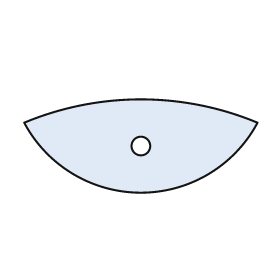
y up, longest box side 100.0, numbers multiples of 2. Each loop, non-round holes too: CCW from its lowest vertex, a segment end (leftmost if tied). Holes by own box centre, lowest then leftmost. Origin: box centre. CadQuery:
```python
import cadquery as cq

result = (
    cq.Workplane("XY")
    .moveTo(-50.0, 10.0)
    .threePointArc((0.0, -20.0), (50.0, 10.0))
    .threePointArc((0.0, 20.0), (-50.0, 10.0))
    .close()
    .moveTo(0.0, 0.0)
    .circle(4.0)
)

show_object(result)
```